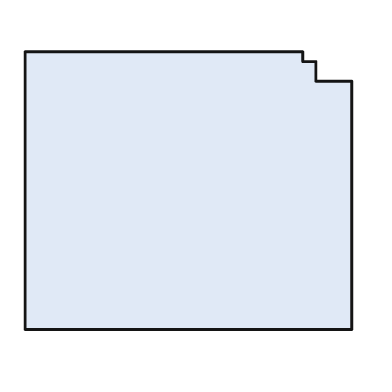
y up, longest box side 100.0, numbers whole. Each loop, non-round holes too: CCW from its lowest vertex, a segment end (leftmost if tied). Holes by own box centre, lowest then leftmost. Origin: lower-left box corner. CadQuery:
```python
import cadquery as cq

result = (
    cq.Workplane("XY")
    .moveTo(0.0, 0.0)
    .lineTo(100.0, 0.0)
    .lineTo(100.0, 76.0)
    .lineTo(89.0, 76.0)
    .lineTo(89.0, 82.0)
    .lineTo(85.0, 82.0)
    .lineTo(85.0, 85.0)
    .lineTo(0.0, 85.0)
    .close()
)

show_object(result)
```